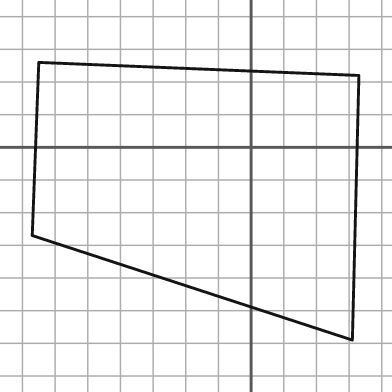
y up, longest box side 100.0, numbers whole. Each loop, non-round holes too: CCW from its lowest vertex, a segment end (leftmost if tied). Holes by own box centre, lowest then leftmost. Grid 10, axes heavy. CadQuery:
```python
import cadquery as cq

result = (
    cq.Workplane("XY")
    .moveTo(31.0, -59.0)
    .lineTo(33.0, 22.0)
    .lineTo(-65.0, 26.0)
    .lineTo(-67.0, -27.0)
    .close()
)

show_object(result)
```